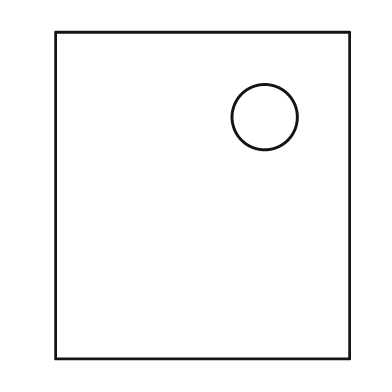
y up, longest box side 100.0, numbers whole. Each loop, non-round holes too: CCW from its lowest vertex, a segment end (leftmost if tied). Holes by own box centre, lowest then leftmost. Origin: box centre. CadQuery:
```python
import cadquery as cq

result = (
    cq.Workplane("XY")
    .moveTo(-45.0, -50.0)
    .lineTo(45.0, -50.0)
    .lineTo(45.0, 50.0)
    .lineTo(-45.0, 50.0)
    .close()
    .moveTo(19.0, 24.0)
    .circle(10.0)
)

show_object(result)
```